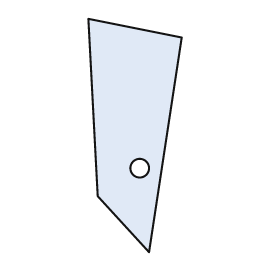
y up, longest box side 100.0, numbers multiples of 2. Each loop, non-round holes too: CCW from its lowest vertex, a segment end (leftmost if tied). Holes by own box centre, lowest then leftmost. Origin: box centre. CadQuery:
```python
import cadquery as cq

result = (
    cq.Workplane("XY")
    .moveTo(6.0, -50.0)
    .lineTo(20.0, 42.0)
    .lineTo(-20.0, 50.0)
    .lineTo(-16.0, -26.0)
    .close()
    .moveTo(2.0, -14.0)
    .circle(4.0)
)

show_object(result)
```